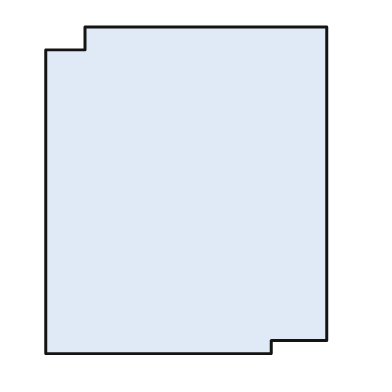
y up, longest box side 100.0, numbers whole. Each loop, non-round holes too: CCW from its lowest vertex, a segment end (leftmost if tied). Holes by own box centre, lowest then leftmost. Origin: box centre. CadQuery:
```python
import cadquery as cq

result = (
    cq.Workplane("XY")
    .moveTo(-43.0, -50.0)
    .lineTo(26.0, -50.0)
    .lineTo(26.0, -46.0)
    .lineTo(43.0, -46.0)
    .lineTo(43.0, 50.0)
    .lineTo(-31.0, 50.0)
    .lineTo(-31.0, 43.0)
    .lineTo(-43.0, 43.0)
    .close()
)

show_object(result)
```